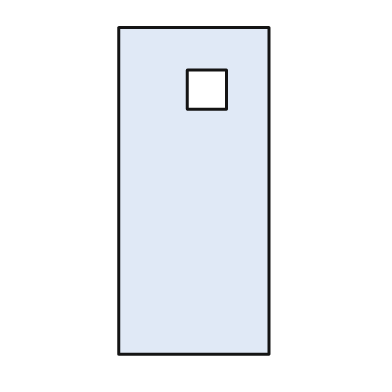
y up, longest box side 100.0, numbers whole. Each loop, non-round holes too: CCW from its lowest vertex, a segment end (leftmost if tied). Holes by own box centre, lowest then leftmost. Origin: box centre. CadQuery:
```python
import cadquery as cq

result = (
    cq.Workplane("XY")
    .moveTo(-23.0, -50.0)
    .lineTo(23.0, -50.0)
    .lineTo(23.0, 50.0)
    .lineTo(-23.0, 50.0)
    .close()
    .moveTo(-2.0, 25.0)
    .lineTo(10.0, 25.0)
    .lineTo(10.0, 37.0)
    .lineTo(-2.0, 37.0)
    .close()
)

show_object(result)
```